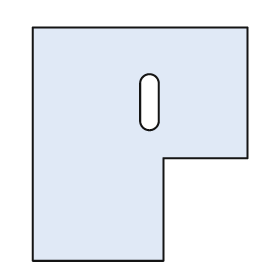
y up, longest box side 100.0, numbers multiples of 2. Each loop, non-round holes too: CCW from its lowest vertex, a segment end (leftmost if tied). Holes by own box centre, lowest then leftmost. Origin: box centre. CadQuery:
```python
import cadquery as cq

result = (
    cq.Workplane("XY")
    .moveTo(-46.0, -50.0)
    .lineTo(10.0, -50.0)
    .lineTo(10.0, -6.0)
    .lineTo(46.0, -6.0)
    .lineTo(46.0, 50.0)
    .lineTo(-46.0, 50.0)
    .close()
    .moveTo(0.0, 10.0)
    .threePointArc((4.0, 6.0), (8.0, 10.0))
    .lineTo(8.0, 26.0)
    .threePointArc((4.0, 30.0), (0.0, 26.0))
    .close()
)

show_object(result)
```